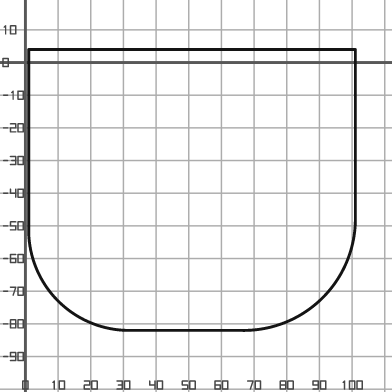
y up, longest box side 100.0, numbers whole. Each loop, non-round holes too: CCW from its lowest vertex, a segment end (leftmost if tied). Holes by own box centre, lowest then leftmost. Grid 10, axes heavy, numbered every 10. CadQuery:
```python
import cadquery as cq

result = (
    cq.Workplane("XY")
    .moveTo(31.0, -82.0)
    .lineTo(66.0, -82.0)
    .threePointArc((91.0, -72.0), (101.0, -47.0))
    .lineTo(101.0, 4.0)
    .lineTo(1.0, 4.0)
    .lineTo(1.0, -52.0)
    .threePointArc((10.0, -73.0), (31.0, -82.0))
    .close()
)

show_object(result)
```